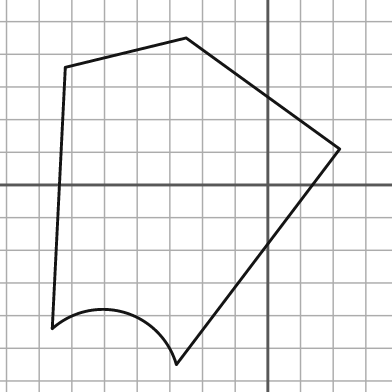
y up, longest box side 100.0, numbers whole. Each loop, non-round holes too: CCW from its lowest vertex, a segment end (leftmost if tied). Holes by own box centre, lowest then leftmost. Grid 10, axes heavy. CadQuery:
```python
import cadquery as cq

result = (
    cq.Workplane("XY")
    .moveTo(-28.0, -55.0)
    .lineTo(22.0, 11.0)
    .lineTo(-25.0, 45.0)
    .lineTo(-62.0, 36.0)
    .lineTo(-66.0, -44.0)
    .threePointArc((-44.0, -39.0), (-28.0, -55.0))
    .close()
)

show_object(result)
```